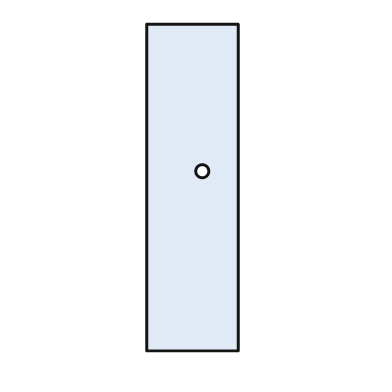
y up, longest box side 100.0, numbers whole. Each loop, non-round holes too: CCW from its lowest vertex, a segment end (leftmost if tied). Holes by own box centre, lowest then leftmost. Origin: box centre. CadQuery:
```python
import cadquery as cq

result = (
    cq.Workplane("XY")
    .moveTo(-14.0, -50.0)
    .lineTo(14.0, -50.0)
    .lineTo(14.0, 50.0)
    .lineTo(-14.0, 50.0)
    .close()
    .moveTo(3.0, 5.0)
    .circle(2.0)
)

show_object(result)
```